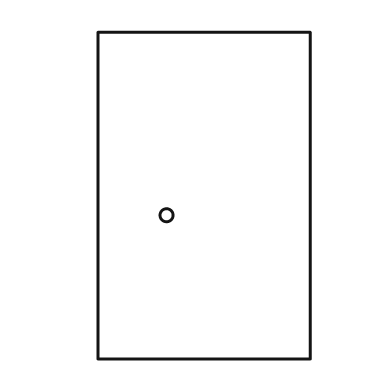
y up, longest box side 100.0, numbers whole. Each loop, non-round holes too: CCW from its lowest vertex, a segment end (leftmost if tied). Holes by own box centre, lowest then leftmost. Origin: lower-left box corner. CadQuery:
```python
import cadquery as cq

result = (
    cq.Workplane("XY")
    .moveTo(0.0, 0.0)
    .lineTo(65.0, 0.0)
    .lineTo(65.0, 100.0)
    .lineTo(0.0, 100.0)
    .close()
    .moveTo(21.0, 44.0)
    .circle(2.0)
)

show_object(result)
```